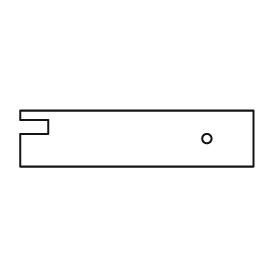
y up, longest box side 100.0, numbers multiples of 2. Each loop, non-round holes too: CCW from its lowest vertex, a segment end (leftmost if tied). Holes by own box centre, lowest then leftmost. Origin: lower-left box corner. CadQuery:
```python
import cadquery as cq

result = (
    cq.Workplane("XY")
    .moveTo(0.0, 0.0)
    .lineTo(100.0, 0.0)
    .lineTo(100.0, 24.0)
    .lineTo(0.0, 24.0)
    .lineTo(0.0, 20.0)
    .lineTo(12.0, 20.0)
    .lineTo(12.0, 14.0)
    .lineTo(0.0, 14.0)
    .close()
    .moveTo(80.0, 12.0)
    .circle(2.0)
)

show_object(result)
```